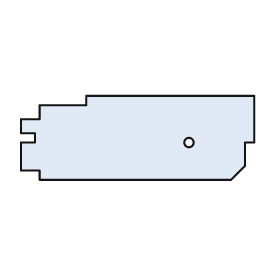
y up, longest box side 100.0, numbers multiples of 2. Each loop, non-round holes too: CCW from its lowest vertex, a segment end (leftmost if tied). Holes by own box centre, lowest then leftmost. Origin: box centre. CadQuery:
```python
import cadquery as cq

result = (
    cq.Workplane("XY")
    .moveTo(-42.0, -18.0)
    .lineTo(40.0, -18.0)
    .lineTo(46.0, -12.0)
    .lineTo(46.0, -2.0)
    .lineTo(50.0, -2.0)
    .lineTo(50.0, 18.0)
    .lineTo(-22.0, 18.0)
    .lineTo(-22.0, 14.0)
    .lineTo(-42.0, 14.0)
    .lineTo(-42.0, 8.0)
    .lineTo(-50.0, 8.0)
    .lineTo(-50.0, 2.0)
    .lineTo(-44.0, 2.0)
    .lineTo(-44.0, -2.0)
    .lineTo(-50.0, -2.0)
    .lineTo(-50.0, -14.0)
    .lineTo(-42.0, -14.0)
    .close()
    .moveTo(22.0, -2.0)
    .circle(2.0)
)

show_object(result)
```